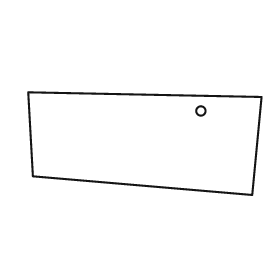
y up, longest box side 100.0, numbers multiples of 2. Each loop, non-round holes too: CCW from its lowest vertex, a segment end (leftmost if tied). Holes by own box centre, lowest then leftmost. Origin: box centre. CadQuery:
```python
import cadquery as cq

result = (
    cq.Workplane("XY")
    .moveTo(46.0, -22.0)
    .lineTo(50.0, 20.0)
    .lineTo(-50.0, 22.0)
    .lineTo(-48.0, -14.0)
    .close()
    .moveTo(24.0, 14.0)
    .circle(2.0)
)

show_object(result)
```